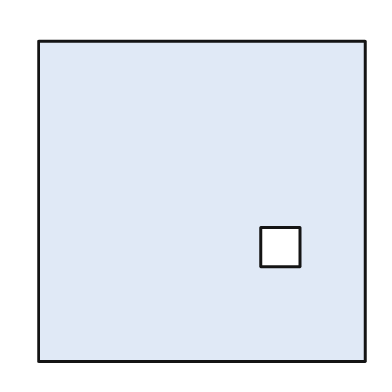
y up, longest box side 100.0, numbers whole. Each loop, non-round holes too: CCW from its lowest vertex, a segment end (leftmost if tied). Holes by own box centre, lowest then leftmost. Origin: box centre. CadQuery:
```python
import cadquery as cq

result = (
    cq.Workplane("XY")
    .moveTo(-50.0, -49.0)
    .lineTo(50.0, -49.0)
    .lineTo(50.0, 49.0)
    .lineTo(-50.0, 49.0)
    .close()
    .moveTo(18.0, -20.0)
    .lineTo(30.0, -20.0)
    .lineTo(30.0, -8.0)
    .lineTo(18.0, -8.0)
    .close()
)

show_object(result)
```